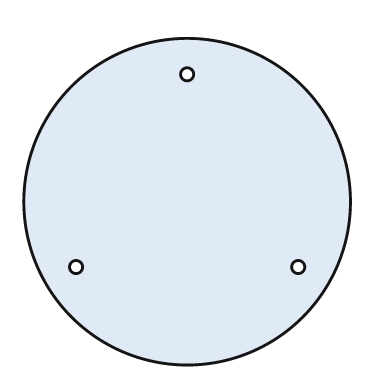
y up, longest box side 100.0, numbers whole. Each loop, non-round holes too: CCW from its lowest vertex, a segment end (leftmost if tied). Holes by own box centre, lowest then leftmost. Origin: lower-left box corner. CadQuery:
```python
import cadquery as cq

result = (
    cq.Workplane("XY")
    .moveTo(50.0, 50.0)
    .circle(50.0)
    .moveTo(16.0, 30.0)
    .circle(2.0)
    .moveTo(84.0, 30.0)
    .circle(2.0)
    .moveTo(50.0, 89.0)
    .circle(2.0)
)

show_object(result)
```